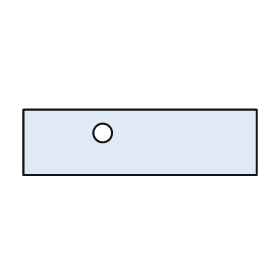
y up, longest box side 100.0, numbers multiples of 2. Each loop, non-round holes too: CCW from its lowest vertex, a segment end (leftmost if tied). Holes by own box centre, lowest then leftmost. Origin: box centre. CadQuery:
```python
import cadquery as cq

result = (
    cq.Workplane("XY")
    .moveTo(-50.0, -14.0)
    .lineTo(50.0, -14.0)
    .lineTo(50.0, 14.0)
    .lineTo(-50.0, 14.0)
    .close()
    .moveTo(-16.0, 4.0)
    .circle(4.0)
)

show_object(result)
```